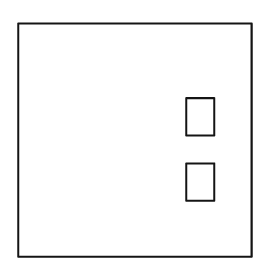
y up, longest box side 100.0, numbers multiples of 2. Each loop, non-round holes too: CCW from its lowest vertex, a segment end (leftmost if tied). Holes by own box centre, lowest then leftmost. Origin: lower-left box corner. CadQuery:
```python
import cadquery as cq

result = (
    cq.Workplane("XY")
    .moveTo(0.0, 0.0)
    .lineTo(100.0, 0.0)
    .lineTo(100.0, 100.0)
    .lineTo(0.0, 100.0)
    .close()
    .moveTo(72.0, 24.0)
    .lineTo(84.0, 24.0)
    .lineTo(84.0, 40.0)
    .lineTo(72.0, 40.0)
    .close()
    .moveTo(72.0, 52.0)
    .lineTo(84.0, 52.0)
    .lineTo(84.0, 68.0)
    .lineTo(72.0, 68.0)
    .close()
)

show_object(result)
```